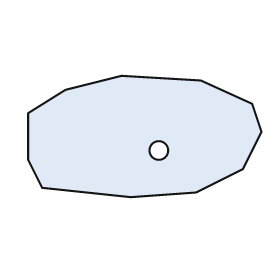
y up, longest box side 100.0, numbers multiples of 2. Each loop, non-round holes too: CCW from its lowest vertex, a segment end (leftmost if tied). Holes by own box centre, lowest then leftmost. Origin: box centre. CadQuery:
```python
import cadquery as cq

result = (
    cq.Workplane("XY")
    .moveTo(-6.0, -26.0)
    .lineTo(22.0, -24.0)
    .lineTo(42.0, -14.0)
    .lineTo(50.0, 2.0)
    .lineTo(46.0, 14.0)
    .lineTo(24.0, 24.0)
    .lineTo(-10.0, 26.0)
    .lineTo(-34.0, 20.0)
    .lineTo(-50.0, 10.0)
    .lineTo(-50.0, -10.0)
    .lineTo(-44.0, -22.0)
    .close()
    .moveTo(6.0, -6.0)
    .circle(4.0)
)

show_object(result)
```